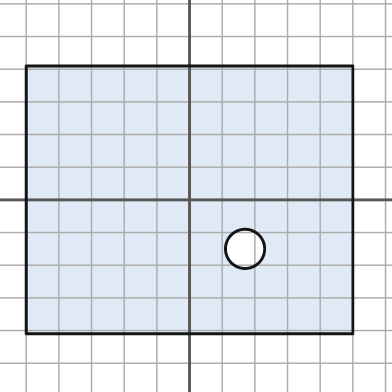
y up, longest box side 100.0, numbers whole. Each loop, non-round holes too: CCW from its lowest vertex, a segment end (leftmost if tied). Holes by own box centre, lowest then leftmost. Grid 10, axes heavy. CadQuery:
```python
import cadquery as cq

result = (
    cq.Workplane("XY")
    .moveTo(-50.0, -41.0)
    .lineTo(50.0, -41.0)
    .lineTo(50.0, 41.0)
    .lineTo(-50.0, 41.0)
    .close()
    .moveTo(17.0, -15.0)
    .circle(6.0)
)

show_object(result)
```